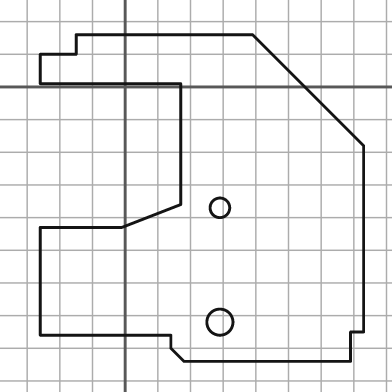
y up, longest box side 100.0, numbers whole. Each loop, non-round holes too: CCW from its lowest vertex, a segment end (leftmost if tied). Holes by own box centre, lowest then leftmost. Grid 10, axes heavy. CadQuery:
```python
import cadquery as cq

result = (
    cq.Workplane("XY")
    .moveTo(18.0, -84.0)
    .lineTo(69.0, -84.0)
    .lineTo(69.0, -75.0)
    .lineTo(73.0, -75.0)
    .lineTo(73.0, -18.0)
    .lineTo(39.0, 16.0)
    .lineTo(-15.0, 16.0)
    .lineTo(-15.0, 10.0)
    .lineTo(-26.0, 10.0)
    .lineTo(-26.0, 1.0)
    .lineTo(17.0, 1.0)
    .lineTo(17.0, -36.0)
    .lineTo(-1.0, -43.0)
    .lineTo(-26.0, -43.0)
    .lineTo(-26.0, -76.0)
    .lineTo(14.0, -76.0)
    .lineTo(14.0, -80.0)
    .close()
    .moveTo(29.0, -72.0)
    .circle(4.0)
    .moveTo(29.0, -37.0)
    .circle(3.0)
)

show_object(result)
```